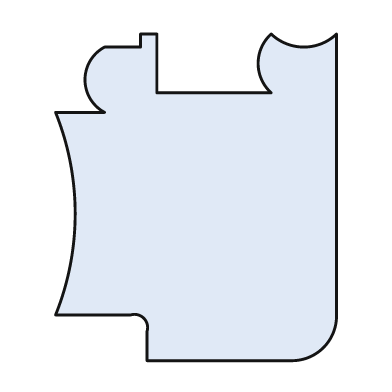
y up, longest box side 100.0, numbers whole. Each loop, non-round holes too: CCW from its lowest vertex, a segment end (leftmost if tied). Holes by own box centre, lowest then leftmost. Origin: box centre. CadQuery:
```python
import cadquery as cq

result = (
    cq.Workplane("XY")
    .moveTo(-15.0, -50.0)
    .lineTo(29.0, -50.0)
    .threePointArc((39.0, -46.0), (43.0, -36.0))
    .lineTo(43.0, 50.0)
    .threePointArc((33.0, 46.0), (23.0, 50.0))
    .threePointArc((19.0, 41.0), (23.0, 32.0))
    .lineTo(-12.0, 32.0)
    .lineTo(-12.0, 50.0)
    .lineTo(-17.0, 50.0)
    .lineTo(-17.0, 46.0)
    .lineTo(-28.0, 46.0)
    .threePointArc((-34.0, 36.0), (-28.0, 26.0))
    .lineTo(-43.0, 26.0)
    .threePointArc((-37.0, -5.0), (-43.0, -36.0))
    .lineTo(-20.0, -36.0)
    .threePointArc((-16.0, -37.0), (-15.0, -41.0))
    .close()
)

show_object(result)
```